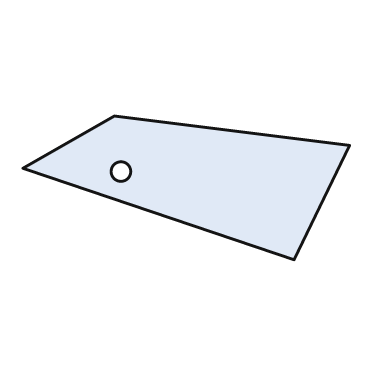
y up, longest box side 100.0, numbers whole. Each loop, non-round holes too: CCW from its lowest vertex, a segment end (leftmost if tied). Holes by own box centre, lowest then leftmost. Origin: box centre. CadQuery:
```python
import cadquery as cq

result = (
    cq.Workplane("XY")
    .moveTo(33.0, -22.0)
    .lineTo(50.0, 13.0)
    .lineTo(-22.0, 22.0)
    .lineTo(-50.0, 6.0)
    .close()
    .moveTo(-20.0, 5.0)
    .circle(3.0)
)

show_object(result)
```